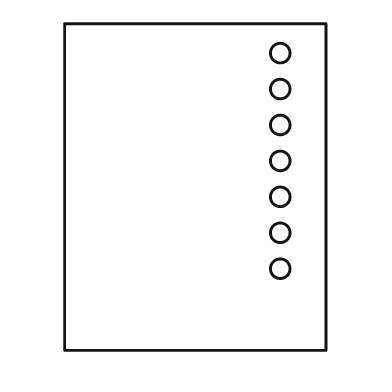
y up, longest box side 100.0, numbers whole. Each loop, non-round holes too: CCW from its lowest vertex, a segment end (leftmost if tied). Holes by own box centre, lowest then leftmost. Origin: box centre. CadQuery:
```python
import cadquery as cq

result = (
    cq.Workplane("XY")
    .moveTo(-40.0, -50.0)
    .lineTo(40.0, -50.0)
    .lineTo(40.0, 50.0)
    .lineTo(-40.0, 50.0)
    .close()
    .moveTo(26.0, -25.0)
    .circle(3.0)
    .moveTo(26.0, -14.0)
    .circle(3.0)
    .moveTo(26.0, -3.0)
    .circle(3.0)
    .moveTo(26.0, 8.0)
    .circle(3.0)
    .moveTo(26.0, 19.0)
    .circle(3.0)
    .moveTo(26.0, 30.0)
    .circle(3.0)
    .moveTo(26.0, 41.0)
    .circle(3.0)
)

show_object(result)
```